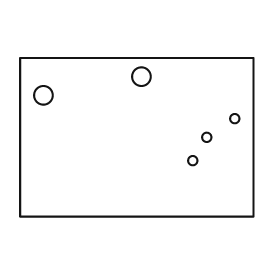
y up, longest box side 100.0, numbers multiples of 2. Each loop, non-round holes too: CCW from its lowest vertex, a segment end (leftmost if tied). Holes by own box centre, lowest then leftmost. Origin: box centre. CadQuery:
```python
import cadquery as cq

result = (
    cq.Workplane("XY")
    .moveTo(-50.0, -34.0)
    .lineTo(50.0, -34.0)
    .lineTo(50.0, 34.0)
    .lineTo(-50.0, 34.0)
    .close()
    .moveTo(24.0, -10.0)
    .circle(2.0)
    .moveTo(30.0, 0.0)
    .circle(2.0)
    .moveTo(42.0, 8.0)
    .circle(2.0)
    .moveTo(-40.0, 18.0)
    .circle(4.0)
    .moveTo(2.0, 26.0)
    .circle(4.0)
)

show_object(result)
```